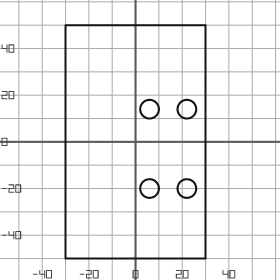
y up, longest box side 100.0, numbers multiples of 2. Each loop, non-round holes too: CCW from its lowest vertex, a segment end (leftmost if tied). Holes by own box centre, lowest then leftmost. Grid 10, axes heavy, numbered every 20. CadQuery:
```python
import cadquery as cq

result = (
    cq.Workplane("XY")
    .moveTo(-30.0, -50.0)
    .lineTo(30.0, -50.0)
    .lineTo(30.0, 50.0)
    .lineTo(-30.0, 50.0)
    .close()
    .moveTo(6.0, -20.0)
    .circle(4.0)
    .moveTo(22.0, -20.0)
    .circle(4.0)
    .moveTo(6.0, 14.0)
    .circle(4.0)
    .moveTo(22.0, 14.0)
    .circle(4.0)
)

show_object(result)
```